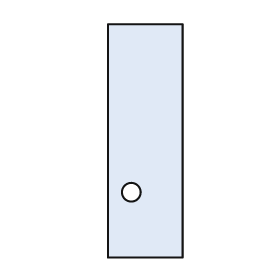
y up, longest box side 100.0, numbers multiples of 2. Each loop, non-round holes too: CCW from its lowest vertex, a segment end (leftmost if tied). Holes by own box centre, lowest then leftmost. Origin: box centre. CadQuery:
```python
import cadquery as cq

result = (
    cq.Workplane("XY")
    .moveTo(-16.0, -50.0)
    .lineTo(16.0, -50.0)
    .lineTo(16.0, 50.0)
    .lineTo(-16.0, 50.0)
    .close()
    .moveTo(-6.0, -22.0)
    .circle(4.0)
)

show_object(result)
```